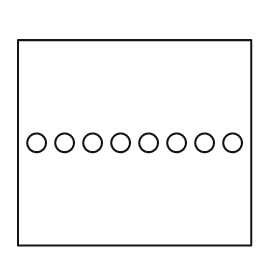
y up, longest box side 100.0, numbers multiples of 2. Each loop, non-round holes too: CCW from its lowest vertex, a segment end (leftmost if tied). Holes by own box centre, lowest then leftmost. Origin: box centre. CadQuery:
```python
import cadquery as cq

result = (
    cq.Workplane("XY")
    .moveTo(-50.0, -44.0)
    .lineTo(50.0, -44.0)
    .lineTo(50.0, 44.0)
    .lineTo(-50.0, 44.0)
    .close()
    .moveTo(-42.0, 0.0)
    .circle(4.0)
    .moveTo(-30.0, 0.0)
    .circle(4.0)
    .moveTo(-18.0, 0.0)
    .circle(4.0)
    .moveTo(-6.0, 0.0)
    .circle(4.0)
    .moveTo(6.0, 0.0)
    .circle(4.0)
    .moveTo(18.0, 0.0)
    .circle(4.0)
    .moveTo(30.0, 0.0)
    .circle(4.0)
    .moveTo(42.0, 0.0)
    .circle(4.0)
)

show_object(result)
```